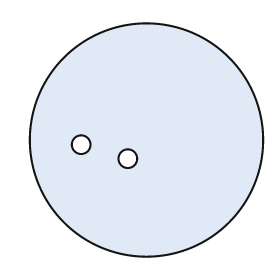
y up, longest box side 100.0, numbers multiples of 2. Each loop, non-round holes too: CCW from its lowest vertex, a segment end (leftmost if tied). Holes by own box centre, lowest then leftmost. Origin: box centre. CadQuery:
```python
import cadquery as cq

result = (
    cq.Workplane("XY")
    .moveTo(0.0, 0.0)
    .circle(50.0)
    .moveTo(-8.0, -8.0)
    .circle(4.0)
    .moveTo(-28.0, -2.0)
    .circle(4.0)
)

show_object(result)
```